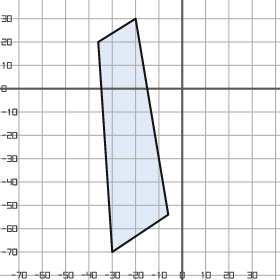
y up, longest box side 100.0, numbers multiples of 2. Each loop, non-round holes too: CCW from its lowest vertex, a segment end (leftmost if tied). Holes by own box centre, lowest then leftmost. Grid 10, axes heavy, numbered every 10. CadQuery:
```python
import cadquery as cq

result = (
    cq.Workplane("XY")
    .moveTo(-30.0, -70.0)
    .lineTo(-6.0, -54.0)
    .lineTo(-20.0, 30.0)
    .lineTo(-36.0, 20.0)
    .close()
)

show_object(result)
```